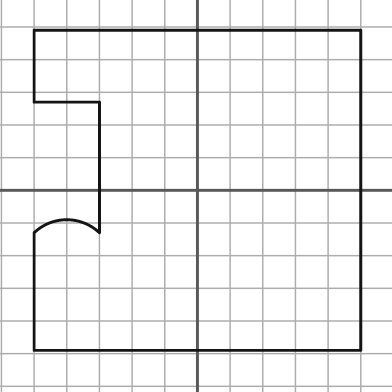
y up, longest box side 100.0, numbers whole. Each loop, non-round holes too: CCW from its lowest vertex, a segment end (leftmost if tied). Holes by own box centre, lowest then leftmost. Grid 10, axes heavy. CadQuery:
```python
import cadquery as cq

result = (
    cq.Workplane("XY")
    .moveTo(-50.0, -49.0)
    .lineTo(50.0, -49.0)
    .lineTo(50.0, 49.0)
    .lineTo(-50.0, 49.0)
    .lineTo(-50.0, 27.0)
    .lineTo(-30.0, 27.0)
    .lineTo(-30.0, -13.0)
    .threePointArc((-40.0, -9.0), (-50.0, -13.0))
    .close()
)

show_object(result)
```